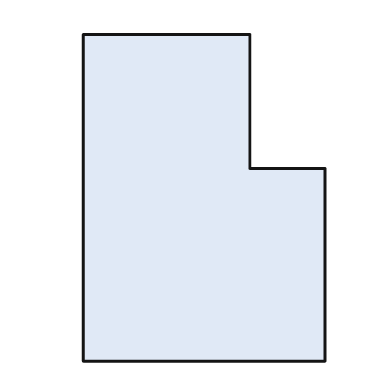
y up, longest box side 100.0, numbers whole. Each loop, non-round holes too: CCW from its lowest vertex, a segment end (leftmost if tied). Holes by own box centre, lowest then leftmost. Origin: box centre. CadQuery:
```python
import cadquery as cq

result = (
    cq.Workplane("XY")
    .moveTo(-37.0, -50.0)
    .lineTo(37.0, -50.0)
    .lineTo(37.0, 9.0)
    .lineTo(14.0, 9.0)
    .lineTo(14.0, 50.0)
    .lineTo(-37.0, 50.0)
    .close()
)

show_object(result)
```